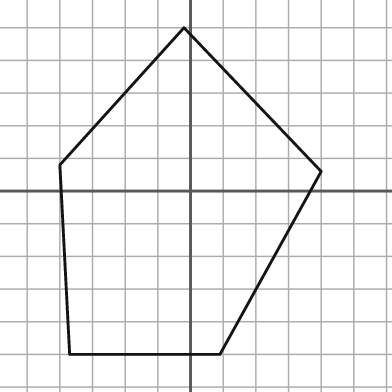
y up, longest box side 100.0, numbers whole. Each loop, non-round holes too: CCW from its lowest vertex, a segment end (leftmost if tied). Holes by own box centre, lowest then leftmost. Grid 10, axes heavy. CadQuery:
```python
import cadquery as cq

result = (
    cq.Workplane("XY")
    .moveTo(-37.0, -50.0)
    .lineTo(9.0, -50.0)
    .lineTo(40.0, 6.0)
    .lineTo(-2.0, 50.0)
    .lineTo(-40.0, 8.0)
    .close()
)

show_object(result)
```